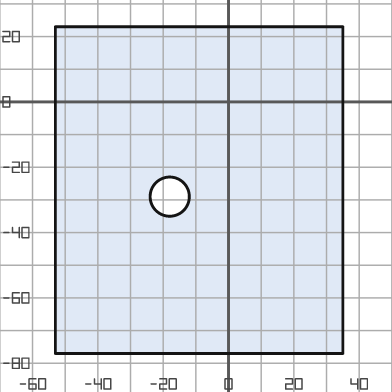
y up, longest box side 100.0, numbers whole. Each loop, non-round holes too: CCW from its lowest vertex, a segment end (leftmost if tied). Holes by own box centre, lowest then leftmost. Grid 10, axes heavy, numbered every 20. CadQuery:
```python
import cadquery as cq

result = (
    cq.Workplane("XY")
    .moveTo(-53.0, -77.0)
    .lineTo(35.0, -77.0)
    .lineTo(35.0, 23.0)
    .lineTo(-53.0, 23.0)
    .close()
    .moveTo(-18.0, -29.0)
    .circle(6.0)
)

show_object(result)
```